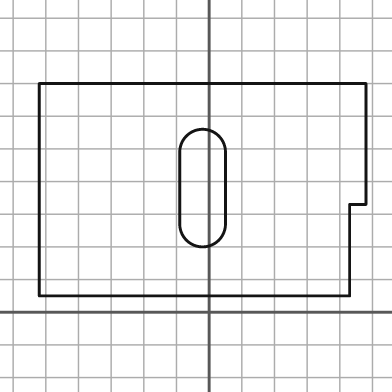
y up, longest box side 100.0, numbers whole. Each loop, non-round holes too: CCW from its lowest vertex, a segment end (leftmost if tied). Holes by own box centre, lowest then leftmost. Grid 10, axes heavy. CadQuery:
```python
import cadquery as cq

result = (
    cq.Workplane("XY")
    .moveTo(-52.0, 5.0)
    .lineTo(43.0, 5.0)
    .lineTo(43.0, 33.0)
    .lineTo(48.0, 33.0)
    .lineTo(48.0, 70.0)
    .lineTo(-52.0, 70.0)
    .close()
    .moveTo(-9.0, 27.0)
    .threePointArc((-2.0, 20.0), (5.0, 27.0))
    .lineTo(5.0, 49.0)
    .threePointArc((-2.0, 56.0), (-9.0, 49.0))
    .close()
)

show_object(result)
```